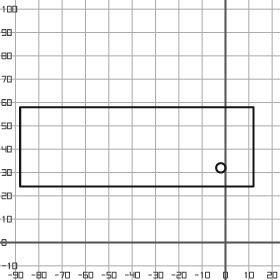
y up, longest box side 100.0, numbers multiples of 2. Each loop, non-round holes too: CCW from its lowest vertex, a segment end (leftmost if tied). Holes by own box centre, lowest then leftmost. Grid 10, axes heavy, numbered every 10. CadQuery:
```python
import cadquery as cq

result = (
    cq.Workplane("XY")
    .moveTo(-88.0, 24.0)
    .lineTo(12.0, 24.0)
    .lineTo(12.0, 58.0)
    .lineTo(-88.0, 58.0)
    .close()
    .moveTo(-2.0, 32.0)
    .circle(2.0)
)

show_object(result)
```